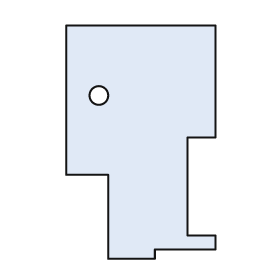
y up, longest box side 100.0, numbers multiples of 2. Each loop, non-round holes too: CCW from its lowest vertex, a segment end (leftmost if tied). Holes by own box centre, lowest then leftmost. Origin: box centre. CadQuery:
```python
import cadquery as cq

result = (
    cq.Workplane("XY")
    .moveTo(-14.0, -50.0)
    .lineTo(6.0, -50.0)
    .lineTo(6.0, -46.0)
    .lineTo(32.0, -46.0)
    .lineTo(32.0, -40.0)
    .lineTo(20.0, -40.0)
    .lineTo(20.0, 2.0)
    .lineTo(32.0, 2.0)
    .lineTo(32.0, 50.0)
    .lineTo(-32.0, 50.0)
    .lineTo(-32.0, -14.0)
    .lineTo(-14.0, -14.0)
    .close()
    .moveTo(-18.0, 20.0)
    .circle(4.0)
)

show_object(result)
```